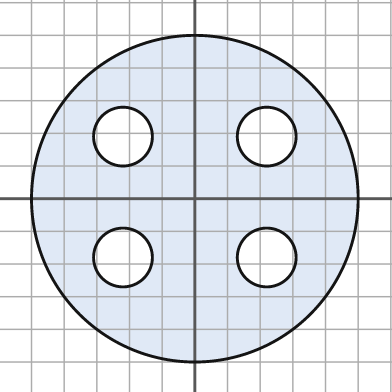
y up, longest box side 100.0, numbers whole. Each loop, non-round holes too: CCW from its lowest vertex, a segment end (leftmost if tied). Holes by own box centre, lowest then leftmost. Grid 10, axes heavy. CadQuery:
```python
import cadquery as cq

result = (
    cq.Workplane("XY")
    .moveTo(0.0, 0.0)
    .circle(50.0)
    .moveTo(-22.0, -18.0)
    .circle(9.0)
    .moveTo(22.0, -18.0)
    .circle(9.0)
    .moveTo(-22.0, 19.0)
    .circle(9.0)
    .moveTo(22.0, 19.0)
    .circle(9.0)
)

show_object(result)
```